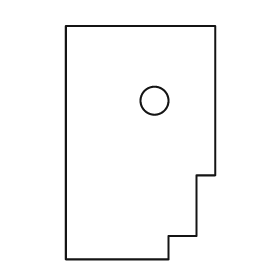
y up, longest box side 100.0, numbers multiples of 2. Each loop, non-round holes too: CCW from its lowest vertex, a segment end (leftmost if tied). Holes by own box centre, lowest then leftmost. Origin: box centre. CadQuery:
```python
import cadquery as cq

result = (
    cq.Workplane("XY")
    .moveTo(-32.0, -50.0)
    .lineTo(12.0, -50.0)
    .lineTo(12.0, -40.0)
    .lineTo(24.0, -40.0)
    .lineTo(24.0, -14.0)
    .lineTo(32.0, -14.0)
    .lineTo(32.0, 50.0)
    .lineTo(-32.0, 50.0)
    .close()
    .moveTo(6.0, 18.0)
    .circle(6.0)
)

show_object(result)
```